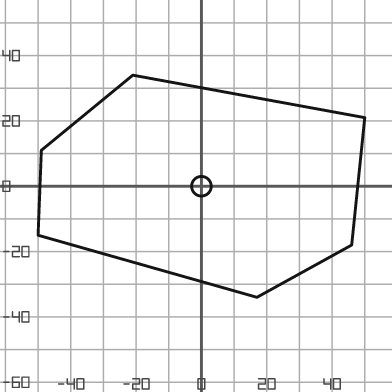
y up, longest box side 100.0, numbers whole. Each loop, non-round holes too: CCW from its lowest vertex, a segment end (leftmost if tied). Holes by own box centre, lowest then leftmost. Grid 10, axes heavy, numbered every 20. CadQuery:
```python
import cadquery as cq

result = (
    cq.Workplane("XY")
    .moveTo(17.0, -34.0)
    .lineTo(46.0, -18.0)
    .lineTo(50.0, 21.0)
    .lineTo(-21.0, 34.0)
    .lineTo(-49.0, 11.0)
    .lineTo(-50.0, -15.0)
    .close()
    .moveTo(0.0, 0.0)
    .circle(3.0)
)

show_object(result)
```